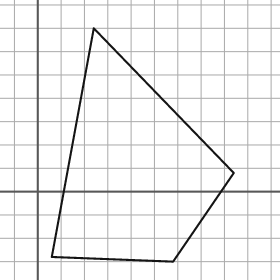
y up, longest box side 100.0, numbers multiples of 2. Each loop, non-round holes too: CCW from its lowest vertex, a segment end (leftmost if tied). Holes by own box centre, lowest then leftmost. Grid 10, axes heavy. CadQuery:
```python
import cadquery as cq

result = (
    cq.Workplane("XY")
    .moveTo(58.0, -30.0)
    .lineTo(84.0, 8.0)
    .lineTo(24.0, 70.0)
    .lineTo(6.0, -28.0)
    .close()
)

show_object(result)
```